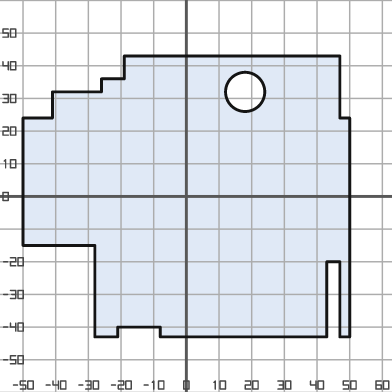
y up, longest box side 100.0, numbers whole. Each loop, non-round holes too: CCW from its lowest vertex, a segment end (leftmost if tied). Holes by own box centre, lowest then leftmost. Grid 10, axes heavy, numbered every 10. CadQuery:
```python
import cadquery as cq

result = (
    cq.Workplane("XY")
    .moveTo(-28.0, -43.0)
    .lineTo(-21.0, -43.0)
    .lineTo(-21.0, -40.0)
    .lineTo(-8.0, -40.0)
    .lineTo(-8.0, -43.0)
    .lineTo(43.0, -43.0)
    .lineTo(43.0, -20.0)
    .lineTo(47.0, -20.0)
    .lineTo(47.0, -43.0)
    .lineTo(50.0, -43.0)
    .lineTo(50.0, 24.0)
    .lineTo(47.0, 24.0)
    .lineTo(47.0, 43.0)
    .lineTo(-19.0, 43.0)
    .lineTo(-19.0, 36.0)
    .lineTo(-26.0, 36.0)
    .lineTo(-26.0, 32.0)
    .lineTo(-41.0, 32.0)
    .lineTo(-41.0, 24.0)
    .lineTo(-50.0, 24.0)
    .lineTo(-50.0, -15.0)
    .lineTo(-28.0, -15.0)
    .close()
    .moveTo(18.0, 32.0)
    .circle(6.0)
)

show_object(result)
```